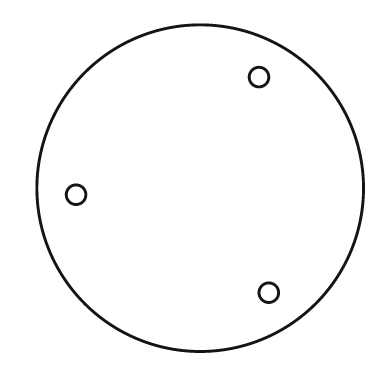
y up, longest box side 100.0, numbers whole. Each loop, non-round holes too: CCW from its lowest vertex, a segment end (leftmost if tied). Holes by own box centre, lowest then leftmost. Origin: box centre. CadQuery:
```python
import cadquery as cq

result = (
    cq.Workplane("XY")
    .moveTo(0.0, 0.0)
    .circle(50.0)
    .moveTo(21.0, -32.0)
    .circle(3.0)
    .moveTo(-38.0, -2.0)
    .circle(3.0)
    .moveTo(18.0, 34.0)
    .circle(3.0)
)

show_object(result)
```